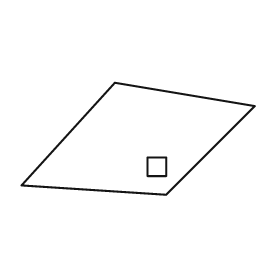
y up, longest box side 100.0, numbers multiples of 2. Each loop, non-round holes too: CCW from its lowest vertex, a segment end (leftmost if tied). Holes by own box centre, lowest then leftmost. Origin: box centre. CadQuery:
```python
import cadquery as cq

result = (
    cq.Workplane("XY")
    .moveTo(12.0, -24.0)
    .lineTo(50.0, 14.0)
    .lineTo(-10.0, 24.0)
    .lineTo(-50.0, -20.0)
    .close()
    .moveTo(4.0, -16.0)
    .lineTo(12.0, -16.0)
    .lineTo(12.0, -8.0)
    .lineTo(4.0, -8.0)
    .close()
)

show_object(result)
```